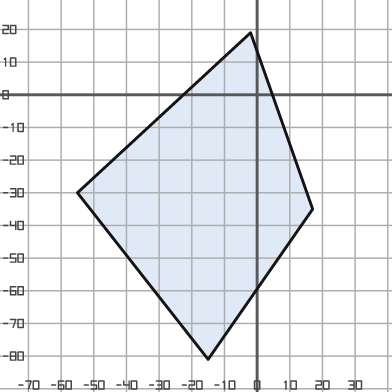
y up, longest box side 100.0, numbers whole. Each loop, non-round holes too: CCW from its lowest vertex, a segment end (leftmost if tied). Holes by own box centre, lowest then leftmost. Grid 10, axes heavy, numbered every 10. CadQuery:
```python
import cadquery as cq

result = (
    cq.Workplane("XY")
    .moveTo(-15.0, -81.0)
    .lineTo(17.0, -35.0)
    .lineTo(-2.0, 19.0)
    .lineTo(-55.0, -30.0)
    .close()
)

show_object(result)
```